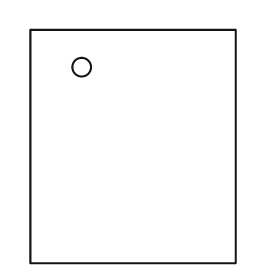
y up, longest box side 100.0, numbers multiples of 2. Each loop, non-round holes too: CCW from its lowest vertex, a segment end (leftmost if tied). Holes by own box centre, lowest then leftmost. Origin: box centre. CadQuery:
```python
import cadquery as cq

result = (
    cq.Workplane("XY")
    .moveTo(-44.0, -50.0)
    .lineTo(44.0, -50.0)
    .lineTo(44.0, 50.0)
    .lineTo(-44.0, 50.0)
    .close()
    .moveTo(-22.0, 34.0)
    .circle(4.0)
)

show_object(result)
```